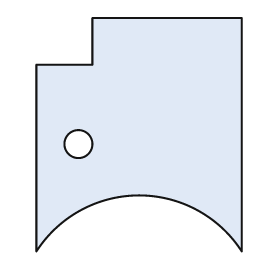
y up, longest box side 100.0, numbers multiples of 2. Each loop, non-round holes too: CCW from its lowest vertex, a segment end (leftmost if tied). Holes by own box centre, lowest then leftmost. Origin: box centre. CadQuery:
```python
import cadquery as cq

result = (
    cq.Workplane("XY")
    .moveTo(-44.0, -50.0)
    .threePointArc((0.0, -26.0), (44.0, -50.0))
    .lineTo(44.0, 50.0)
    .lineTo(-20.0, 50.0)
    .lineTo(-20.0, 30.0)
    .lineTo(-44.0, 30.0)
    .close()
    .moveTo(-26.0, -4.0)
    .circle(6.0)
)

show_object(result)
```